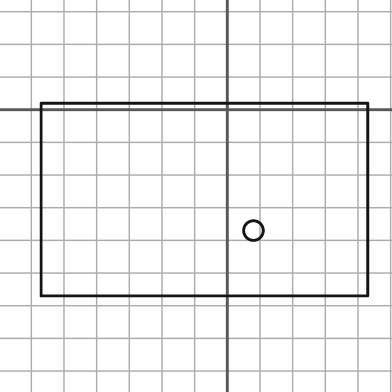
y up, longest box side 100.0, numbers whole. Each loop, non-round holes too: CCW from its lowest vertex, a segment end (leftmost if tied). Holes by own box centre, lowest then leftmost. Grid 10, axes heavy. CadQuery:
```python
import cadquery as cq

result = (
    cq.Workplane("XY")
    .moveTo(-57.0, -57.0)
    .lineTo(43.0, -57.0)
    .lineTo(43.0, 2.0)
    .lineTo(-57.0, 2.0)
    .close()
    .moveTo(8.0, -37.0)
    .circle(3.0)
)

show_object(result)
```